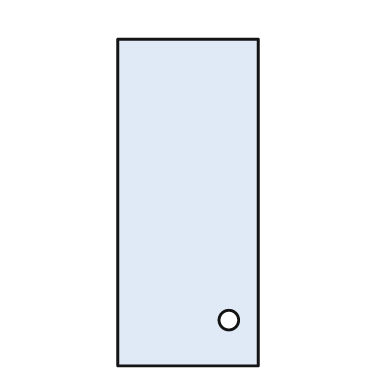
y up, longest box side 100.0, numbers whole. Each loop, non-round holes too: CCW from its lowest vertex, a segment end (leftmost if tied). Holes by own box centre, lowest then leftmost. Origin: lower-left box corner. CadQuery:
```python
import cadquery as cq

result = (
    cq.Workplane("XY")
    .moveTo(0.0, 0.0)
    .lineTo(43.0, 0.0)
    .lineTo(43.0, 100.0)
    .lineTo(0.0, 100.0)
    .close()
    .moveTo(34.0, 14.0)
    .circle(3.0)
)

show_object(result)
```